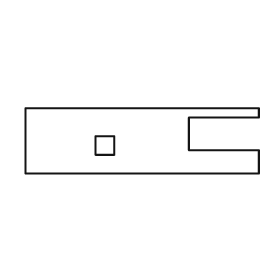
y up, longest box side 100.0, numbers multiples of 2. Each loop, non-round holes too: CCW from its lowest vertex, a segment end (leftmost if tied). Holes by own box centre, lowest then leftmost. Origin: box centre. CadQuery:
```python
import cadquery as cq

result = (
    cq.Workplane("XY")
    .moveTo(-50.0, -14.0)
    .lineTo(50.0, -14.0)
    .lineTo(50.0, -4.0)
    .lineTo(20.0, -4.0)
    .lineTo(20.0, 10.0)
    .lineTo(50.0, 10.0)
    .lineTo(50.0, 14.0)
    .lineTo(-50.0, 14.0)
    .close()
    .moveTo(-20.0, -6.0)
    .lineTo(-12.0, -6.0)
    .lineTo(-12.0, 2.0)
    .lineTo(-20.0, 2.0)
    .close()
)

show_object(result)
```